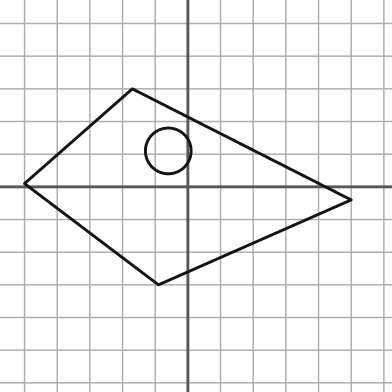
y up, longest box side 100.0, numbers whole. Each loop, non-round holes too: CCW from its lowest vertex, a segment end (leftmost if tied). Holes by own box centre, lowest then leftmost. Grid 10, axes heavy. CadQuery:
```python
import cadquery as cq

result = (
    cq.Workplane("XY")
    .moveTo(-9.0, -30.0)
    .lineTo(50.0, -4.0)
    .lineTo(-17.0, 30.0)
    .lineTo(-50.0, 1.0)
    .close()
    .moveTo(-6.0, 11.0)
    .circle(7.0)
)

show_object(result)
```